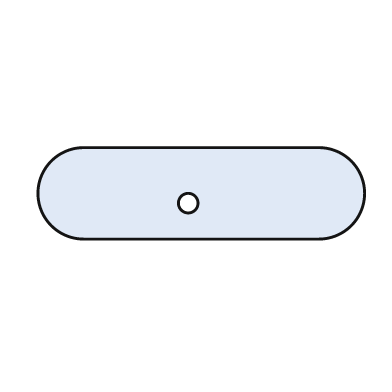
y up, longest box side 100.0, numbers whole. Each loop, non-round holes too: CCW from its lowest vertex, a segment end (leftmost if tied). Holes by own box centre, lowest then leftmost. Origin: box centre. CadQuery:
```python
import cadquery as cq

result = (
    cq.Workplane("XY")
    .moveTo(-36.0, -14.0)
    .lineTo(36.0, -14.0)
    .threePointArc((50.0, 0.0), (36.0, 14.0))
    .lineTo(-36.0, 14.0)
    .threePointArc((-50.0, 0.0), (-36.0, -14.0))
    .close()
    .moveTo(-4.0, -3.0)
    .circle(3.0)
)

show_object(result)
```